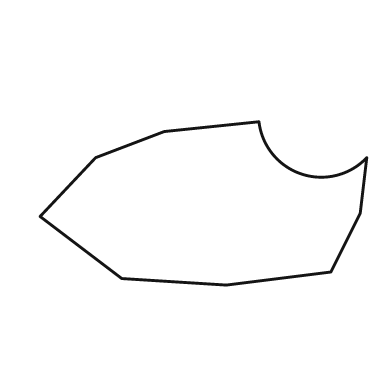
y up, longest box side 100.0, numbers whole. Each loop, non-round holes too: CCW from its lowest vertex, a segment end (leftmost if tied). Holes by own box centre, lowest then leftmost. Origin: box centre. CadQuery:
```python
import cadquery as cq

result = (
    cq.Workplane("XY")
    .moveTo(7.0, -25.0)
    .lineTo(39.0, -21.0)
    .lineTo(48.0, -3.0)
    .lineTo(50.0, 14.0)
    .threePointArc((30.0, 9.0), (17.0, 25.0))
    .lineTo(-12.0, 22.0)
    .lineTo(-33.0, 14.0)
    .lineTo(-50.0, -4.0)
    .lineTo(-25.0, -23.0)
    .close()
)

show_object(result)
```